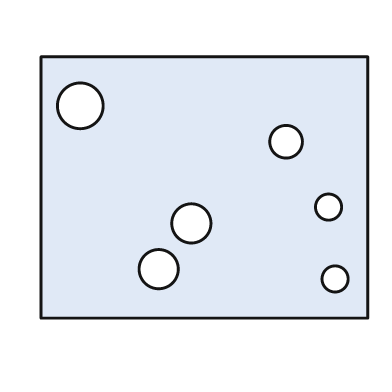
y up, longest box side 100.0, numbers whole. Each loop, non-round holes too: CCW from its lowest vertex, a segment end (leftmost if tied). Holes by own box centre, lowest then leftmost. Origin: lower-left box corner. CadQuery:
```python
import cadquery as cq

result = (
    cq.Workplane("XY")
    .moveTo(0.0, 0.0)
    .lineTo(100.0, 0.0)
    .lineTo(100.0, 80.0)
    .lineTo(0.0, 80.0)
    .close()
    .moveTo(90.0, 12.0)
    .circle(4.0)
    .moveTo(36.0, 15.0)
    .circle(6.0)
    .moveTo(46.0, 29.0)
    .circle(6.0)
    .moveTo(88.0, 34.0)
    .circle(4.0)
    .moveTo(75.0, 54.0)
    .circle(5.0)
    .moveTo(12.0, 65.0)
    .circle(7.0)
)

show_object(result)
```